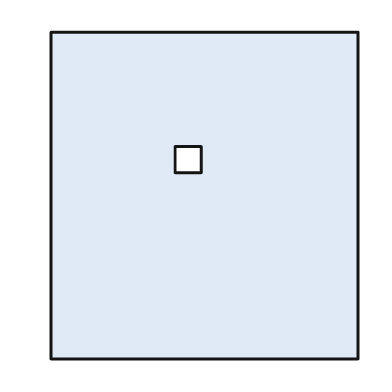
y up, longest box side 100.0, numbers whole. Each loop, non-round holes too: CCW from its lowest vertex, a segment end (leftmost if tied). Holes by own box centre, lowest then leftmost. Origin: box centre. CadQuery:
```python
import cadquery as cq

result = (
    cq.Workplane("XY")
    .moveTo(-47.0, -50.0)
    .lineTo(47.0, -50.0)
    .lineTo(47.0, 50.0)
    .lineTo(-47.0, 50.0)
    .close()
    .moveTo(-9.0, 7.0)
    .lineTo(-1.0, 7.0)
    .lineTo(-1.0, 15.0)
    .lineTo(-9.0, 15.0)
    .close()
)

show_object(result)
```